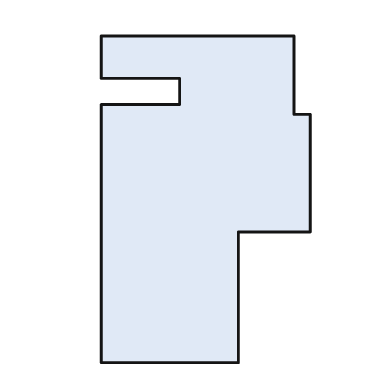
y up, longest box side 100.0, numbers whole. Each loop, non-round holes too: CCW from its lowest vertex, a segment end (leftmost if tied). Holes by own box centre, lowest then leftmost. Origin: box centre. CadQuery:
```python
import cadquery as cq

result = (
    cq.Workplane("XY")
    .moveTo(-32.0, -50.0)
    .lineTo(10.0, -50.0)
    .lineTo(10.0, -10.0)
    .lineTo(32.0, -10.0)
    .lineTo(32.0, 26.0)
    .lineTo(27.0, 26.0)
    .lineTo(27.0, 50.0)
    .lineTo(-32.0, 50.0)
    .lineTo(-32.0, 37.0)
    .lineTo(-8.0, 37.0)
    .lineTo(-8.0, 29.0)
    .lineTo(-32.0, 29.0)
    .close()
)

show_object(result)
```